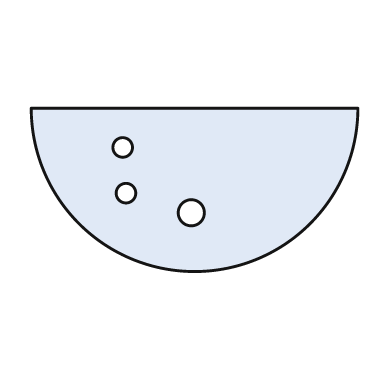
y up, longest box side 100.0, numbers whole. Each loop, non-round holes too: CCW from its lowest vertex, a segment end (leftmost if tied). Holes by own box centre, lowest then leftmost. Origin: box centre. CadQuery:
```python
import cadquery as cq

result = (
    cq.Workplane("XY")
    .moveTo(-50.0, 25.0)
    .threePointArc((0.0, -25.0), (50.0, 25.0))
    .close()
    .moveTo(-1.0, -7.0)
    .circle(4.0)
    .moveTo(-21.0, -1.0)
    .circle(3.0)
    .moveTo(-22.0, 13.0)
    .circle(3.0)
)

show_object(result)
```